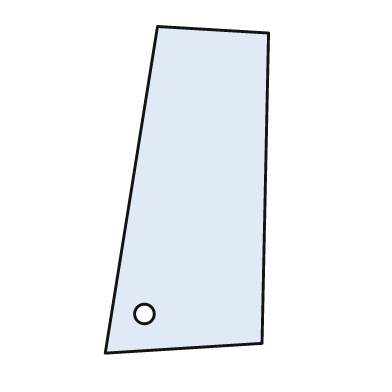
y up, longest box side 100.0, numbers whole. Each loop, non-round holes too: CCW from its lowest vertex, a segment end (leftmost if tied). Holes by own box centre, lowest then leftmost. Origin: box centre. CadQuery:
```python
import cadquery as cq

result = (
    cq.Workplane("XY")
    .moveTo(-25.0, -50.0)
    .lineTo(23.0, -47.0)
    .lineTo(25.0, 48.0)
    .lineTo(-9.0, 50.0)
    .close()
    .moveTo(-13.0, -38.0)
    .circle(3.0)
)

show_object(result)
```